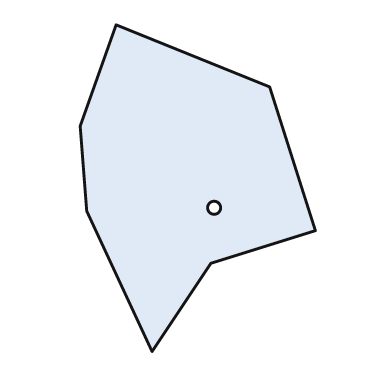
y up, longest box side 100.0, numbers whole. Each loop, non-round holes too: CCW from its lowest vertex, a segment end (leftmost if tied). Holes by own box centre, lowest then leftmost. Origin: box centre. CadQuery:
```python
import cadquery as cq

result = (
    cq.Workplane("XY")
    .moveTo(-14.0, -50.0)
    .lineTo(4.0, -23.0)
    .lineTo(36.0, -13.0)
    .lineTo(22.0, 31.0)
    .lineTo(-25.0, 50.0)
    .lineTo(-36.0, 19.0)
    .lineTo(-34.0, -7.0)
    .close()
    .moveTo(5.0, -6.0)
    .circle(2.0)
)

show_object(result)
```